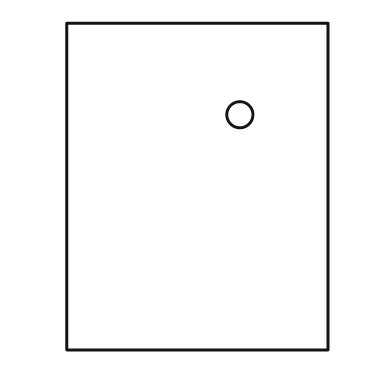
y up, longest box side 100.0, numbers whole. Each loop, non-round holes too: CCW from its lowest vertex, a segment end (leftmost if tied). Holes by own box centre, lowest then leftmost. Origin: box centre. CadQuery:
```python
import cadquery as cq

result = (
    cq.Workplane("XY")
    .moveTo(-40.0, -50.0)
    .lineTo(40.0, -50.0)
    .lineTo(40.0, 50.0)
    .lineTo(-40.0, 50.0)
    .close()
    .moveTo(13.0, 22.0)
    .circle(4.0)
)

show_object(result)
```